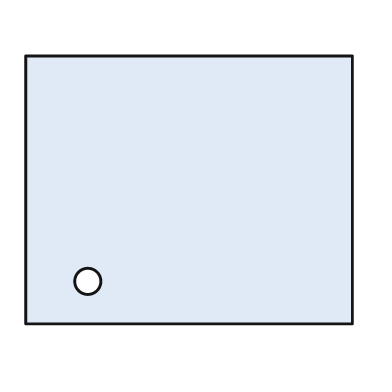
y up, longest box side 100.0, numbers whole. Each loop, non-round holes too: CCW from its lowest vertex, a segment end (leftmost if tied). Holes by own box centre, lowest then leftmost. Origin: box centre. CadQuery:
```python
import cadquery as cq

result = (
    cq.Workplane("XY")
    .moveTo(-50.0, -41.0)
    .lineTo(50.0, -41.0)
    .lineTo(50.0, 41.0)
    .lineTo(-50.0, 41.0)
    .close()
    .moveTo(-31.0, -28.0)
    .circle(4.0)
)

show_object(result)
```